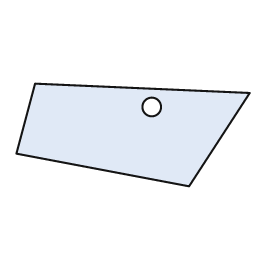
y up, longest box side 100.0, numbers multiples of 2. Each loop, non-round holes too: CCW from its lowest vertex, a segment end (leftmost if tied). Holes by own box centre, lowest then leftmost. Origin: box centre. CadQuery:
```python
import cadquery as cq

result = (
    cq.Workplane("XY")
    .moveTo(24.0, -22.0)
    .lineTo(50.0, 18.0)
    .lineTo(-42.0, 22.0)
    .lineTo(-50.0, -8.0)
    .close()
    .moveTo(8.0, 12.0)
    .circle(4.0)
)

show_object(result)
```